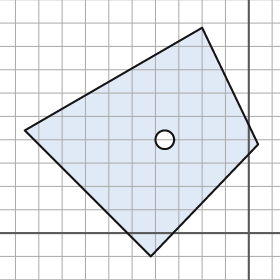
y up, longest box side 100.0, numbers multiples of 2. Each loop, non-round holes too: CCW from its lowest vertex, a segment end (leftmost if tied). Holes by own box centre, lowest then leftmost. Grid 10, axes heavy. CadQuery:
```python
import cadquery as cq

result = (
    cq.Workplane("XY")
    .moveTo(-42.0, -10.0)
    .lineTo(4.0, 38.0)
    .lineTo(-20.0, 88.0)
    .lineTo(-96.0, 44.0)
    .close()
    .moveTo(-36.0, 40.0)
    .circle(4.0)
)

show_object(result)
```